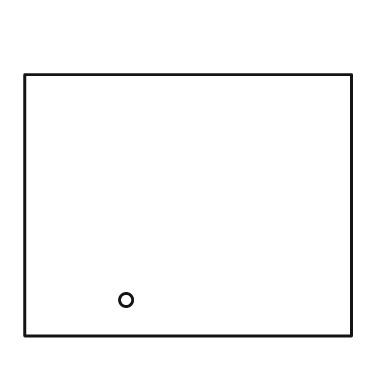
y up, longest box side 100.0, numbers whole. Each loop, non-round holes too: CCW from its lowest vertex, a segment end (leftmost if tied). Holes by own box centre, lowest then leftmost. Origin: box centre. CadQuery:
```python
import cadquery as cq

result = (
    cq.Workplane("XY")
    .moveTo(-50.0, -40.0)
    .lineTo(50.0, -40.0)
    .lineTo(50.0, 40.0)
    .lineTo(-50.0, 40.0)
    .close()
    .moveTo(-19.0, -29.0)
    .circle(2.0)
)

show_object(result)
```